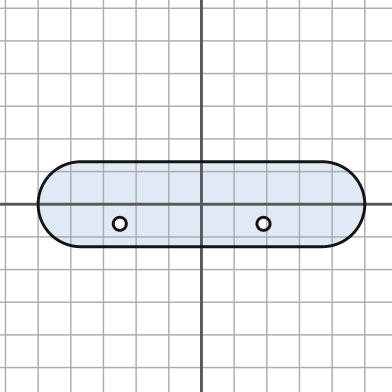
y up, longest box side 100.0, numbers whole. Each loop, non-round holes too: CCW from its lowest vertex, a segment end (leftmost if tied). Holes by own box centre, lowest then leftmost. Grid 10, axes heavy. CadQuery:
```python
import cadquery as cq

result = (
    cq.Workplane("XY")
    .moveTo(-37.0, -13.0)
    .lineTo(37.0, -13.0)
    .threePointArc((50.0, 0.0), (37.0, 13.0))
    .lineTo(-37.0, 13.0)
    .threePointArc((-50.0, 0.0), (-37.0, -13.0))
    .close()
    .moveTo(-25.0, -6.0)
    .circle(2.0)
    .moveTo(19.0, -6.0)
    .circle(2.0)
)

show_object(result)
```